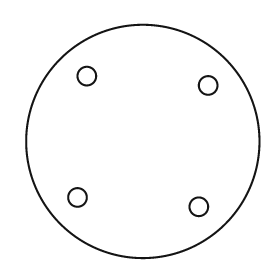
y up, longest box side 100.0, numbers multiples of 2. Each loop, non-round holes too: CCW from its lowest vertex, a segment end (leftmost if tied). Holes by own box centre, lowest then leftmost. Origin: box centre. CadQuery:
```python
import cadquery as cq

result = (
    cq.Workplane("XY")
    .moveTo(0.0, 0.0)
    .circle(50.0)
    .moveTo(24.0, -28.0)
    .circle(4.0)
    .moveTo(-28.0, -24.0)
    .circle(4.0)
    .moveTo(28.0, 24.0)
    .circle(4.0)
    .moveTo(-24.0, 28.0)
    .circle(4.0)
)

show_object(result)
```